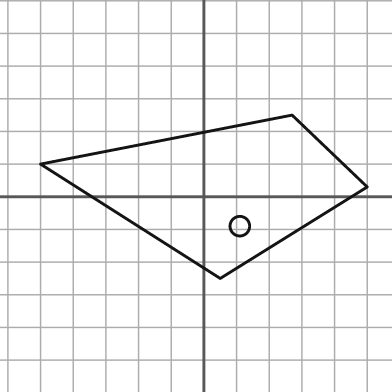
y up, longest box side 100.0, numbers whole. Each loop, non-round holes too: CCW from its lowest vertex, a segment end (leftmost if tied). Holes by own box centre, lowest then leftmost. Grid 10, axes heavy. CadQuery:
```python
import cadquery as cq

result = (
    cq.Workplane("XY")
    .moveTo(5.0, -25.0)
    .lineTo(50.0, 3.0)
    .lineTo(27.0, 25.0)
    .lineTo(-50.0, 10.0)
    .close()
    .moveTo(11.0, -9.0)
    .circle(3.0)
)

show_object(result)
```